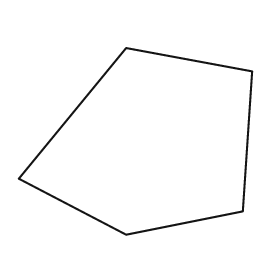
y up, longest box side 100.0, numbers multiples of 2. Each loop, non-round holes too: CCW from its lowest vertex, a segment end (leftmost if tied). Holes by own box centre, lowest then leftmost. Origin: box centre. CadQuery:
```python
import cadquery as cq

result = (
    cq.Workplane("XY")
    .moveTo(-4.0, -40.0)
    .lineTo(46.0, -30.0)
    .lineTo(50.0, 30.0)
    .lineTo(-4.0, 40.0)
    .lineTo(-50.0, -16.0)
    .close()
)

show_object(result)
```